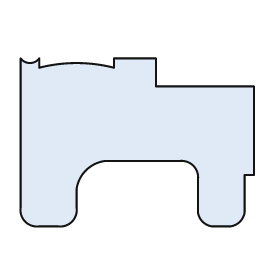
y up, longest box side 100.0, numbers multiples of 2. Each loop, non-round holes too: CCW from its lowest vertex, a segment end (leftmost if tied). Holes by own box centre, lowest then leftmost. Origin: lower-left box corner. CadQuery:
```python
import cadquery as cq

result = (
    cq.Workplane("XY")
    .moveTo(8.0, 0.0)
    .lineTo(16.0, 0.0)
    .threePointArc((22.0, 2.0), (24.0, 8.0))
    .lineTo(24.0, 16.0)
    .threePointArc((28.0, 24.0), (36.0, 28.0))
    .lineTo(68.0, 28.0)
    .threePointArc((74.0, 26.0), (76.0, 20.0))
    .lineTo(76.0, 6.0)
    .threePointArc((78.0, 2.0), (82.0, 0.0))
    .lineTo(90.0, 0.0)
    .threePointArc((94.0, 2.0), (96.0, 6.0))
    .lineTo(96.0, 22.0)
    .lineTo(100.0, 22.0)
    .lineTo(100.0, 60.0)
    .lineTo(58.0, 60.0)
    .lineTo(58.0, 72.0)
    .lineTo(40.0, 72.0)
    .lineTo(40.0, 68.0)
    .threePointArc((24.0, 70.0), (8.0, 68.0))
    .lineTo(8.0, 72.0)
    .threePointArc((4.0, 70.0), (0.0, 72.0))
    .lineTo(0.0, 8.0)
    .threePointArc((2.0, 2.0), (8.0, 0.0))
    .close()
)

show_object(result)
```